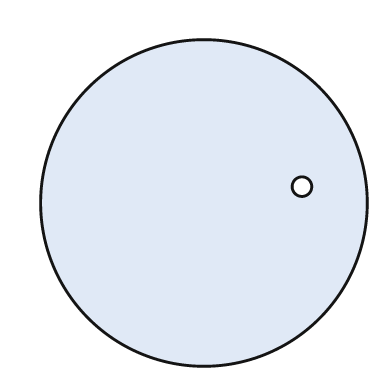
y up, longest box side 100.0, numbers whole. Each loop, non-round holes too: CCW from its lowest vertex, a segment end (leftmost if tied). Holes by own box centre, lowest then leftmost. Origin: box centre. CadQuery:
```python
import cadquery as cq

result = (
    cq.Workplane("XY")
    .moveTo(0.0, 0.0)
    .circle(50.0)
    .moveTo(30.0, 5.0)
    .circle(3.0)
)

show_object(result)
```